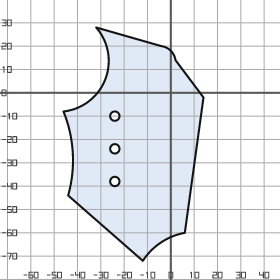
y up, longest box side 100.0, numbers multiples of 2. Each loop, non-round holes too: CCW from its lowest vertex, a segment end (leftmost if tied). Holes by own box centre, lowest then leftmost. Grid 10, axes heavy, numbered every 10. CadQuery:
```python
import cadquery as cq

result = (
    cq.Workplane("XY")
    .moveTo(-12.0, -72.0)
    .threePointArc((-4.0, -64.0), (6.0, -60.0))
    .lineTo(14.0, -2.0)
    .lineTo(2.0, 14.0)
    .threePointArc((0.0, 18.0), (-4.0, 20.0))
    .lineTo(-32.0, 28.0)
    .threePointArc((-28.0, 6.0), (-46.0, -8.0))
    .threePointArc((-42.0, -26.0), (-44.0, -44.0))
    .close()
    .moveTo(-24.0, -38.0)
    .circle(2.0)
    .moveTo(-24.0, -24.0)
    .circle(2.0)
    .moveTo(-24.0, -10.0)
    .circle(2.0)
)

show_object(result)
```